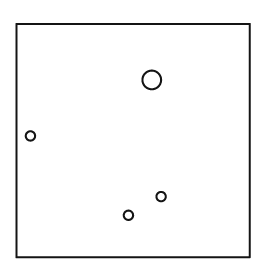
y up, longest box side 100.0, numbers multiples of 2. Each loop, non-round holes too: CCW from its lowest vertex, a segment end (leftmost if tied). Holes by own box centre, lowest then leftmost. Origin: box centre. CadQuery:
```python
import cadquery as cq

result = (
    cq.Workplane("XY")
    .moveTo(-50.0, -50.0)
    .lineTo(50.0, -50.0)
    .lineTo(50.0, 50.0)
    .lineTo(-50.0, 50.0)
    .close()
    .moveTo(-2.0, -32.0)
    .circle(2.0)
    .moveTo(12.0, -24.0)
    .circle(2.0)
    .moveTo(-44.0, 2.0)
    .circle(2.0)
    .moveTo(8.0, 26.0)
    .circle(4.0)
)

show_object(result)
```